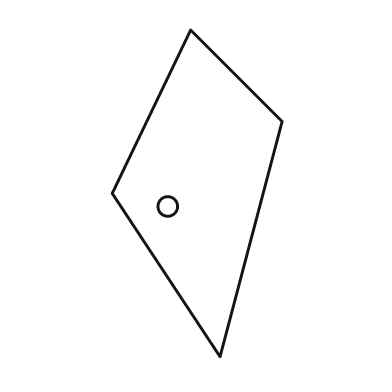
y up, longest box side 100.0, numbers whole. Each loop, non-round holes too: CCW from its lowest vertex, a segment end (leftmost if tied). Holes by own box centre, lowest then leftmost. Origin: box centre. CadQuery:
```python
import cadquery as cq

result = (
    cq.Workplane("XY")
    .moveTo(7.0, -50.0)
    .lineTo(26.0, 22.0)
    .lineTo(-2.0, 50.0)
    .lineTo(-26.0, 0.0)
    .close()
    .moveTo(-9.0, -4.0)
    .circle(3.0)
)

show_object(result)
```